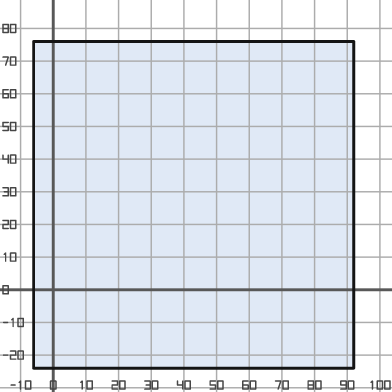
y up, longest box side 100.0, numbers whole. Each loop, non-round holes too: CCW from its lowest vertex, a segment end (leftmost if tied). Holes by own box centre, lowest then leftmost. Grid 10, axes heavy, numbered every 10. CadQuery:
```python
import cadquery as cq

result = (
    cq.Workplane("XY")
    .moveTo(-6.0, -24.0)
    .lineTo(92.0, -24.0)
    .lineTo(92.0, 76.0)
    .lineTo(-6.0, 76.0)
    .close()
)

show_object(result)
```